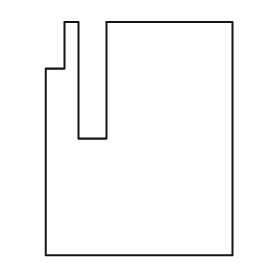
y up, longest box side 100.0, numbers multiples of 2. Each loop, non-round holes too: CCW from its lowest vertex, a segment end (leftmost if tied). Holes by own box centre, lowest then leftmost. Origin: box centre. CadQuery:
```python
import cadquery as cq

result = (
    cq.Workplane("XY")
    .moveTo(-40.0, -50.0)
    .lineTo(40.0, -50.0)
    .lineTo(40.0, 50.0)
    .lineTo(-14.0, 50.0)
    .lineTo(-14.0, 0.0)
    .lineTo(-26.0, 0.0)
    .lineTo(-26.0, 50.0)
    .lineTo(-32.0, 50.0)
    .lineTo(-32.0, 30.0)
    .lineTo(-40.0, 30.0)
    .close()
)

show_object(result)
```